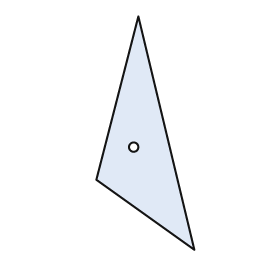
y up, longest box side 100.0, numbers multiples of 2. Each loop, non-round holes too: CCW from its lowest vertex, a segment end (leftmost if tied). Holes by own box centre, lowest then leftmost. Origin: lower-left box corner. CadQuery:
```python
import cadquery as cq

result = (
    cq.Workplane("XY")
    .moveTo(42.0, 0.0)
    .lineTo(18.0, 100.0)
    .lineTo(0.0, 30.0)
    .close()
    .moveTo(16.0, 44.0)
    .circle(2.0)
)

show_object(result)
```